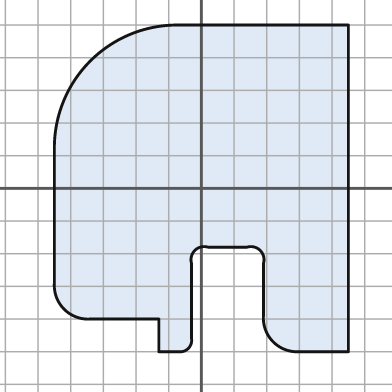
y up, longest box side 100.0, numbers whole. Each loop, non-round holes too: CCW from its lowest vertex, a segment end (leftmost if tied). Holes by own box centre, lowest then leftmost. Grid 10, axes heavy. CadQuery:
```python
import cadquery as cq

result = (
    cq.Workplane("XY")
    .moveTo(-13.0, -50.0)
    .lineTo(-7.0, -50.0)
    .threePointArc((-4.0, -49.0), (-3.0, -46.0))
    .lineTo(-3.0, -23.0)
    .threePointArc((-2.0, -19.0), (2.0, -18.0))
    .lineTo(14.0, -18.0)
    .threePointArc((18.0, -19.0), (19.0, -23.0))
    .lineTo(19.0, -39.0)
    .threePointArc((22.0, -47.0), (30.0, -50.0))
    .lineTo(45.0, -50.0)
    .lineTo(45.0, 50.0)
    .lineTo(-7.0, 50.0)
    .threePointArc((-34.0, 39.0), (-45.0, 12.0))
    .lineTo(-45.0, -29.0)
    .threePointArc((-42.0, -37.0), (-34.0, -40.0))
    .lineTo(-13.0, -40.0)
    .close()
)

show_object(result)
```